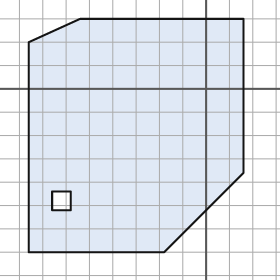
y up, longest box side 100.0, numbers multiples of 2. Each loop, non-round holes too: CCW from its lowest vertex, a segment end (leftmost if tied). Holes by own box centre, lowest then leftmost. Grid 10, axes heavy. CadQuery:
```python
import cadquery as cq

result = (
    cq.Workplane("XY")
    .moveTo(-76.0, -70.0)
    .lineTo(-18.0, -70.0)
    .lineTo(16.0, -36.0)
    .lineTo(16.0, 30.0)
    .lineTo(-54.0, 30.0)
    .lineTo(-76.0, 20.0)
    .close()
    .moveTo(-66.0, -52.0)
    .lineTo(-58.0, -52.0)
    .lineTo(-58.0, -44.0)
    .lineTo(-66.0, -44.0)
    .close()
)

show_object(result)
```